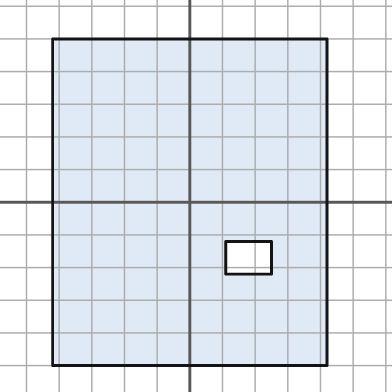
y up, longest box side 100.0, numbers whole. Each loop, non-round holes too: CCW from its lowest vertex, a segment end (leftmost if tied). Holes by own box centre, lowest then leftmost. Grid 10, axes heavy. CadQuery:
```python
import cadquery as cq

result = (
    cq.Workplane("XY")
    .moveTo(-42.0, -50.0)
    .lineTo(42.0, -50.0)
    .lineTo(42.0, 50.0)
    .lineTo(-42.0, 50.0)
    .close()
    .moveTo(11.0, -22.0)
    .lineTo(25.0, -22.0)
    .lineTo(25.0, -12.0)
    .lineTo(11.0, -12.0)
    .close()
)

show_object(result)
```